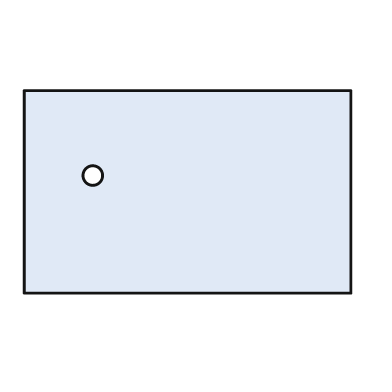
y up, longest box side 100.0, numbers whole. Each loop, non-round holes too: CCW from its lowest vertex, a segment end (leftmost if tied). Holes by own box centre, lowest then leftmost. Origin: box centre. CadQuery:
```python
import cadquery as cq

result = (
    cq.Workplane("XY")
    .moveTo(-50.0, -31.0)
    .lineTo(50.0, -31.0)
    .lineTo(50.0, 31.0)
    .lineTo(-50.0, 31.0)
    .close()
    .moveTo(-29.0, 5.0)
    .circle(3.0)
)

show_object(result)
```